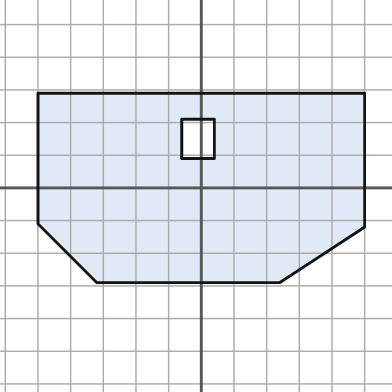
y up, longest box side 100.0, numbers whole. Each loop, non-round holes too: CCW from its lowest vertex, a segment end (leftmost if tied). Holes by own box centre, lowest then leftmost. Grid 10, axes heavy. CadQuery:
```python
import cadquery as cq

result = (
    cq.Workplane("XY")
    .moveTo(-32.0, -29.0)
    .lineTo(24.0, -29.0)
    .lineTo(50.0, -12.0)
    .lineTo(50.0, 29.0)
    .lineTo(-50.0, 29.0)
    .lineTo(-50.0, -11.0)
    .close()
    .moveTo(-6.0, 9.0)
    .lineTo(4.0, 9.0)
    .lineTo(4.0, 21.0)
    .lineTo(-6.0, 21.0)
    .close()
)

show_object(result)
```